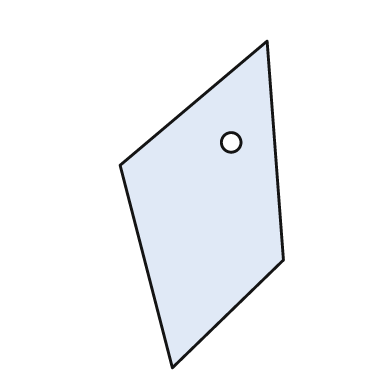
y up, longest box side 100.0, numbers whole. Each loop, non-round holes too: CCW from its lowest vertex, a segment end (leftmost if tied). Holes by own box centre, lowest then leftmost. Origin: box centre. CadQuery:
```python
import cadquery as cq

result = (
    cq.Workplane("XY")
    .moveTo(-9.0, -50.0)
    .lineTo(25.0, -17.0)
    .lineTo(20.0, 50.0)
    .lineTo(-25.0, 12.0)
    .close()
    .moveTo(9.0, 19.0)
    .circle(3.0)
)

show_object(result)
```